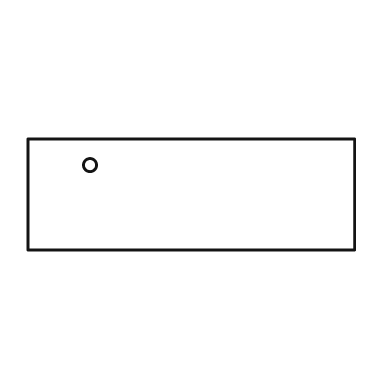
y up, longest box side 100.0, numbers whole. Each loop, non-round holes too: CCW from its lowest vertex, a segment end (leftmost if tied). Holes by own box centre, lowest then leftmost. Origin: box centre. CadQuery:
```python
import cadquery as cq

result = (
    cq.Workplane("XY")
    .moveTo(-50.0, -17.0)
    .lineTo(50.0, -17.0)
    .lineTo(50.0, 17.0)
    .lineTo(-50.0, 17.0)
    .close()
    .moveTo(-31.0, 9.0)
    .circle(2.0)
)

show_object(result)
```